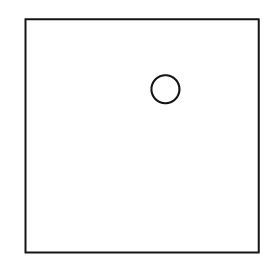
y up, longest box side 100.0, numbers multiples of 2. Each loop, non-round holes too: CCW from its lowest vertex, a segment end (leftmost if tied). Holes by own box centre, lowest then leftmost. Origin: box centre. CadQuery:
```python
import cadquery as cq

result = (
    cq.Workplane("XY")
    .moveTo(-50.0, -50.0)
    .lineTo(50.0, -50.0)
    .lineTo(50.0, 50.0)
    .lineTo(-50.0, 50.0)
    .close()
    .moveTo(10.0, 20.0)
    .circle(6.0)
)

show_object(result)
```